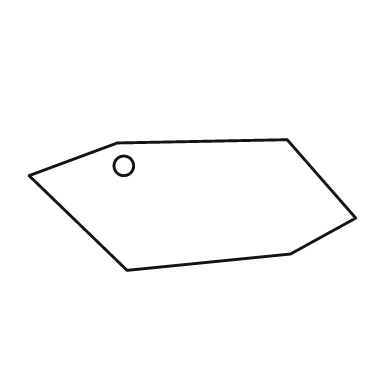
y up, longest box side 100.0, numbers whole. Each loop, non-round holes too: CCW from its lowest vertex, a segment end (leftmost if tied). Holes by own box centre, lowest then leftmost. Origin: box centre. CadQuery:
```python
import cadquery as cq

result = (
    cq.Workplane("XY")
    .moveTo(-20.0, -20.0)
    .lineTo(30.0, -15.0)
    .lineTo(50.0, -4.0)
    .lineTo(29.0, 20.0)
    .lineTo(-23.0, 19.0)
    .lineTo(-50.0, 9.0)
    .close()
    .moveTo(-21.0, 12.0)
    .circle(3.0)
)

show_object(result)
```